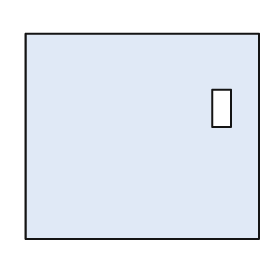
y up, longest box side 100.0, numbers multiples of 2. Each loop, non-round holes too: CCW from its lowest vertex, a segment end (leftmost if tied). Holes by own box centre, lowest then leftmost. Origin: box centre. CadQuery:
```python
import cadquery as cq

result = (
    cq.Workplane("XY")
    .moveTo(-50.0, -44.0)
    .lineTo(50.0, -44.0)
    .lineTo(50.0, 44.0)
    .lineTo(-50.0, 44.0)
    .close()
    .moveTo(30.0, 4.0)
    .lineTo(38.0, 4.0)
    .lineTo(38.0, 20.0)
    .lineTo(30.0, 20.0)
    .close()
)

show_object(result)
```